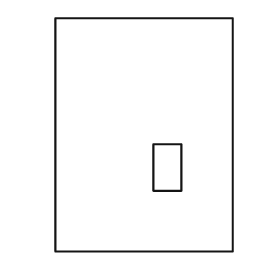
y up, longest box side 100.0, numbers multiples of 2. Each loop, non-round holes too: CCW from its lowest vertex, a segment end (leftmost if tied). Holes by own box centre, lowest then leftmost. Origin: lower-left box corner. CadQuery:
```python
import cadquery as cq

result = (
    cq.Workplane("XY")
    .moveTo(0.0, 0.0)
    .lineTo(76.0, 0.0)
    .lineTo(76.0, 100.0)
    .lineTo(0.0, 100.0)
    .close()
    .moveTo(42.0, 26.0)
    .lineTo(54.0, 26.0)
    .lineTo(54.0, 46.0)
    .lineTo(42.0, 46.0)
    .close()
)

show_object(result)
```